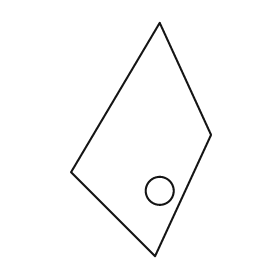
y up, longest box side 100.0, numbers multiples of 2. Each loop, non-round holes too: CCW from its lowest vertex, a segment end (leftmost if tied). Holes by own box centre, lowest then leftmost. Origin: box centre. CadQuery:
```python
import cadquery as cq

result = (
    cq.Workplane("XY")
    .moveTo(6.0, -50.0)
    .lineTo(30.0, 2.0)
    .lineTo(8.0, 50.0)
    .lineTo(-30.0, -14.0)
    .close()
    .moveTo(8.0, -22.0)
    .circle(6.0)
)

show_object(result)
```